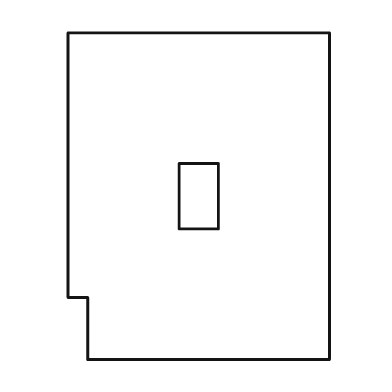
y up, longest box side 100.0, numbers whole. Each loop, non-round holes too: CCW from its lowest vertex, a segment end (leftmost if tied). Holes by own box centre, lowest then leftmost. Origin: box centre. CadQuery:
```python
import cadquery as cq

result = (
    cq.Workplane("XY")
    .moveTo(-34.0, -50.0)
    .lineTo(40.0, -50.0)
    .lineTo(40.0, 50.0)
    .lineTo(-40.0, 50.0)
    .lineTo(-40.0, -31.0)
    .lineTo(-34.0, -31.0)
    .close()
    .moveTo(-6.0, -10.0)
    .lineTo(6.0, -10.0)
    .lineTo(6.0, 10.0)
    .lineTo(-6.0, 10.0)
    .close()
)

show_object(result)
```